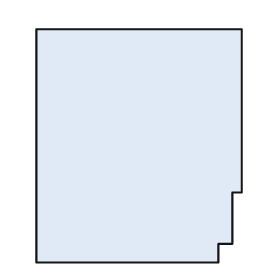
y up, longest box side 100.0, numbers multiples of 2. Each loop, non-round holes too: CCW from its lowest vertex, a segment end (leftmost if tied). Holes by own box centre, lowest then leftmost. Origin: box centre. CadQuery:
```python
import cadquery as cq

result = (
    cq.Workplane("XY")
    .moveTo(-44.0, -50.0)
    .lineTo(34.0, -50.0)
    .lineTo(34.0, -42.0)
    .lineTo(40.0, -42.0)
    .lineTo(40.0, -20.0)
    .lineTo(44.0, -20.0)
    .lineTo(44.0, 50.0)
    .lineTo(-44.0, 50.0)
    .close()
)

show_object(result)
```